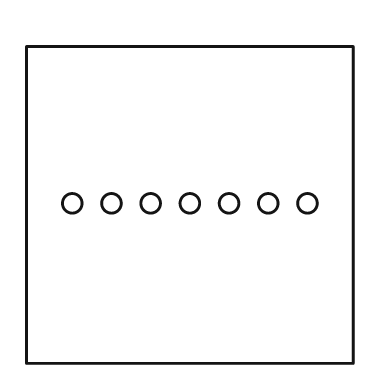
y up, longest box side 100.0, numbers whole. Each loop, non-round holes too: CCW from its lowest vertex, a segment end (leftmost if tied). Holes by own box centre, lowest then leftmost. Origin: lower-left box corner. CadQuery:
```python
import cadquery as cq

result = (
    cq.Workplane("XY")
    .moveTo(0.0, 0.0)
    .lineTo(100.0, 0.0)
    .lineTo(100.0, 97.0)
    .lineTo(0.0, 97.0)
    .close()
    .moveTo(14.0, 49.0)
    .circle(3.0)
    .moveTo(26.0, 49.0)
    .circle(3.0)
    .moveTo(38.0, 49.0)
    .circle(3.0)
    .moveTo(50.0, 49.0)
    .circle(3.0)
    .moveTo(62.0, 49.0)
    .circle(3.0)
    .moveTo(74.0, 49.0)
    .circle(3.0)
    .moveTo(86.0, 49.0)
    .circle(3.0)
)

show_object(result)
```